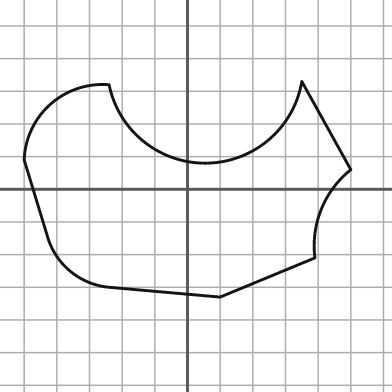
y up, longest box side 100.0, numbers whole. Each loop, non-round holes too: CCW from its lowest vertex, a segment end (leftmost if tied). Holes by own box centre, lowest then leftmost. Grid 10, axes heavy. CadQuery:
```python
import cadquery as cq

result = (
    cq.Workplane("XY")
    .moveTo(10.0, -33.0)
    .lineTo(39.0, -21.0)
    .threePointArc((41.0, -6.0), (50.0, 6.0))
    .lineTo(35.0, 33.0)
    .threePointArc((6.0, 8.0), (-24.0, 32.0))
    .threePointArc((-42.0, 26.0), (-50.0, 9.0))
    .lineTo(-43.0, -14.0)
    .threePointArc((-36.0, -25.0), (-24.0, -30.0))
    .close()
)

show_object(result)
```